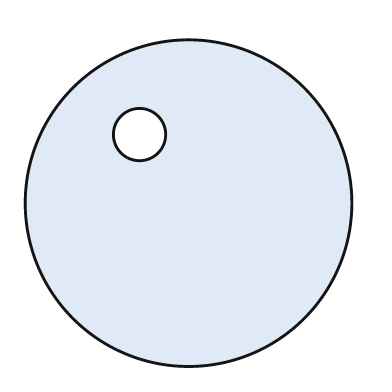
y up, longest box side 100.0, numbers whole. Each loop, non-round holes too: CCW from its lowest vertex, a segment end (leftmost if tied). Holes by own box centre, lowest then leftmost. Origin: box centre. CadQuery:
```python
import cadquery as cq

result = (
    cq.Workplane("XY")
    .moveTo(0.0, 0.0)
    .circle(50.0)
    .moveTo(-15.0, 21.0)
    .circle(8.0)
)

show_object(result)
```